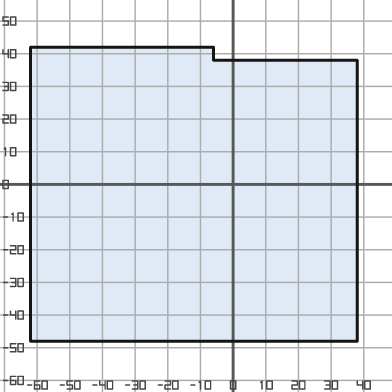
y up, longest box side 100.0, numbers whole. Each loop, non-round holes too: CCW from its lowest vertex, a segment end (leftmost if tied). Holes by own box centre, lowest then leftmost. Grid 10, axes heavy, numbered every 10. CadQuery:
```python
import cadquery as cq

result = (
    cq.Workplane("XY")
    .moveTo(-62.0, -48.0)
    .lineTo(38.0, -48.0)
    .lineTo(38.0, 38.0)
    .lineTo(-6.0, 38.0)
    .lineTo(-6.0, 42.0)
    .lineTo(-62.0, 42.0)
    .close()
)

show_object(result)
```